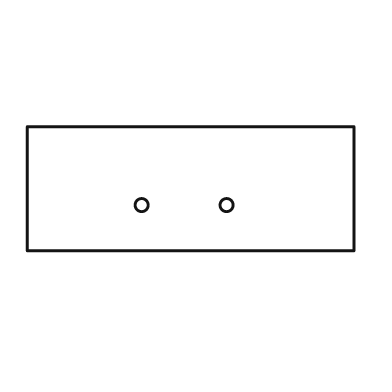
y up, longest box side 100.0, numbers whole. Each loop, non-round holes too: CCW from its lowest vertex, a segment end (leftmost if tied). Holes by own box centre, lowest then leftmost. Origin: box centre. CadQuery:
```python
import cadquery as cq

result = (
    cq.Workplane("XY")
    .moveTo(-50.0, -19.0)
    .lineTo(50.0, -19.0)
    .lineTo(50.0, 19.0)
    .lineTo(-50.0, 19.0)
    .close()
    .moveTo(-15.0, -5.0)
    .circle(2.0)
    .moveTo(11.0, -5.0)
    .circle(2.0)
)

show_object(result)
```